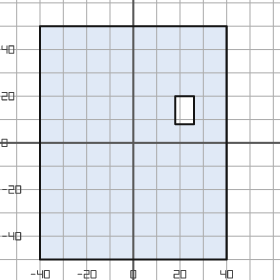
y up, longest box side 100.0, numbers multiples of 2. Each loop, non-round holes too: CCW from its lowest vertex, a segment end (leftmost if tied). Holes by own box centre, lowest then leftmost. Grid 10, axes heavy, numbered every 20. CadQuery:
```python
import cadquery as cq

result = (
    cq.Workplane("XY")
    .moveTo(-40.0, -50.0)
    .lineTo(40.0, -50.0)
    .lineTo(40.0, 50.0)
    .lineTo(-40.0, 50.0)
    .close()
    .moveTo(18.0, 8.0)
    .lineTo(26.0, 8.0)
    .lineTo(26.0, 20.0)
    .lineTo(18.0, 20.0)
    .close()
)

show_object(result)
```